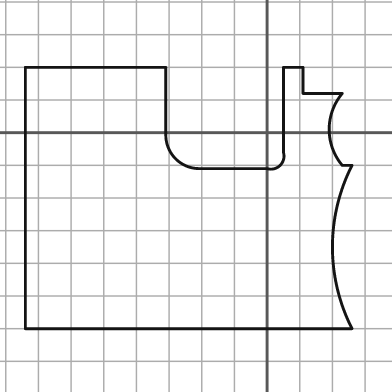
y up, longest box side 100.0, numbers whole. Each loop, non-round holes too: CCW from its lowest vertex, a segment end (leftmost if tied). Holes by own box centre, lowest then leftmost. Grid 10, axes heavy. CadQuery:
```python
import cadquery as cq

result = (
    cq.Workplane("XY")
    .moveTo(-74.0, -60.0)
    .lineTo(26.0, -60.0)
    .threePointArc((20.0, -35.0), (26.0, -10.0))
    .lineTo(23.0, -10.0)
    .threePointArc((19.0, 1.0), (23.0, 12.0))
    .lineTo(11.0, 12.0)
    .lineTo(11.0, 20.0)
    .lineTo(5.0, 20.0)
    .lineTo(5.0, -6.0)
    .threePointArc((4.0, -10.0), (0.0, -11.0))
    .lineTo(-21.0, -11.0)
    .threePointArc((-28.0, -8.0), (-31.0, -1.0))
    .lineTo(-31.0, 20.0)
    .lineTo(-74.0, 20.0)
    .close()
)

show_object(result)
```